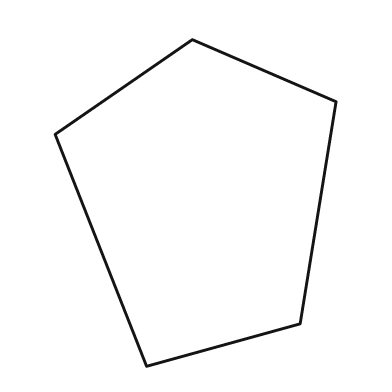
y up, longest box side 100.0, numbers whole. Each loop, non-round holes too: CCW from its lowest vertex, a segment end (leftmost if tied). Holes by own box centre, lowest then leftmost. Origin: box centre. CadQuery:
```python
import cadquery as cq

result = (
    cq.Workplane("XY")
    .moveTo(-15.0, -50.0)
    .lineTo(32.0, -37.0)
    .lineTo(43.0, 31.0)
    .lineTo(-1.0, 50.0)
    .lineTo(-43.0, 21.0)
    .close()
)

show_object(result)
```